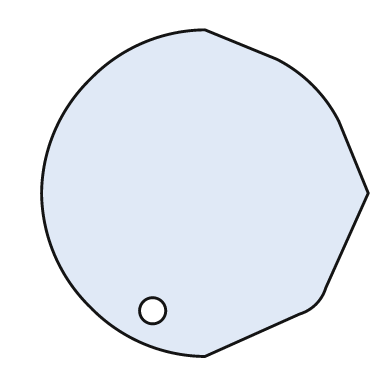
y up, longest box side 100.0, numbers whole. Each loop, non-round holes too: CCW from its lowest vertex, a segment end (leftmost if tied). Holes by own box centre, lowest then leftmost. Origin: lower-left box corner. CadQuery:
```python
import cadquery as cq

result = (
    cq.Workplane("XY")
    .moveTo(50.0, 0.0)
    .lineTo(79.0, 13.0)
    .threePointArc((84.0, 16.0), (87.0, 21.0))
    .lineTo(100.0, 50.0)
    .lineTo(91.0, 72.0)
    .threePointArc((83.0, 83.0), (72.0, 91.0))
    .lineTo(50.0, 100.0)
    .threePointArc((31.0, 96.0), (15.0, 85.0))
    .threePointArc((4.0, 69.0), (0.0, 50.0))
    .threePointArc((4.0, 31.0), (15.0, 15.0))
    .threePointArc((31.0, 4.0), (50.0, 0.0))
    .close()
    .moveTo(34.0, 14.0)
    .circle(4.0)
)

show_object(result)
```